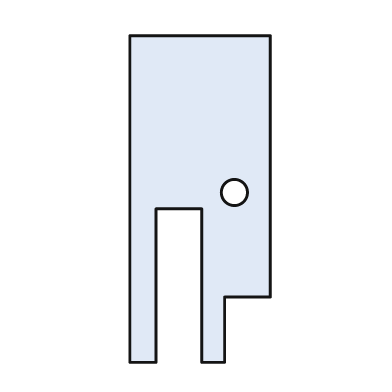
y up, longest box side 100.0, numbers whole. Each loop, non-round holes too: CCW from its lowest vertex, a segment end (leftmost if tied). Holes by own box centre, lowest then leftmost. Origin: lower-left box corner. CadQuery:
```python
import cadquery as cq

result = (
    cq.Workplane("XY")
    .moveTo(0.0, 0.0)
    .lineTo(8.0, 0.0)
    .lineTo(8.0, 47.0)
    .lineTo(22.0, 47.0)
    .lineTo(22.0, 0.0)
    .lineTo(29.0, 0.0)
    .lineTo(29.0, 20.0)
    .lineTo(43.0, 20.0)
    .lineTo(43.0, 100.0)
    .lineTo(0.0, 100.0)
    .close()
    .moveTo(32.0, 52.0)
    .circle(4.0)
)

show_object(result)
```